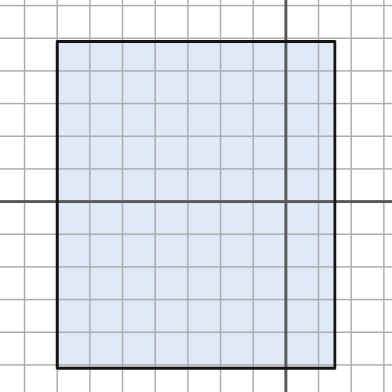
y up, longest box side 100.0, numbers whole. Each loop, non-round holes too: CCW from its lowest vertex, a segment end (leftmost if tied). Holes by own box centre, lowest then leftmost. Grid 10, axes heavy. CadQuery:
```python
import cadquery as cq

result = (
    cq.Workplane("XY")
    .moveTo(-70.0, -51.0)
    .lineTo(15.0, -51.0)
    .lineTo(15.0, 49.0)
    .lineTo(-70.0, 49.0)
    .close()
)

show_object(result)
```